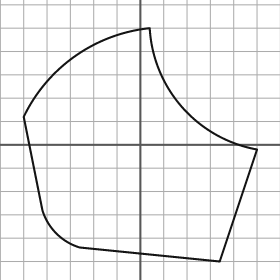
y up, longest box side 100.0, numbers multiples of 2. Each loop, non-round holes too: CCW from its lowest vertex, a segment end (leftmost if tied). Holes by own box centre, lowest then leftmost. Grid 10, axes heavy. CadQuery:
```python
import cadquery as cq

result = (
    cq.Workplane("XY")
    .moveTo(34.0, -50.0)
    .lineTo(50.0, -2.0)
    .threePointArc((18.0, 16.0), (4.0, 50.0))
    .threePointArc((-28.0, 38.0), (-50.0, 12.0))
    .lineTo(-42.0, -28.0)
    .threePointArc((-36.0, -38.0), (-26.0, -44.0))
    .close()
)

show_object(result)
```